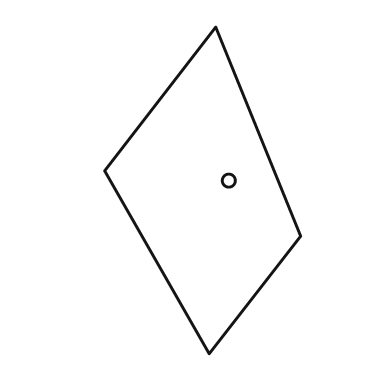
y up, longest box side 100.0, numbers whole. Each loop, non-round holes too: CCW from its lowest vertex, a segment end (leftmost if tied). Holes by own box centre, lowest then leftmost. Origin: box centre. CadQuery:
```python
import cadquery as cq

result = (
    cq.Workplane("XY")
    .moveTo(2.0, -50.0)
    .lineTo(30.0, -14.0)
    .lineTo(4.0, 50.0)
    .lineTo(-30.0, 6.0)
    .close()
    .moveTo(8.0, 3.0)
    .circle(2.0)
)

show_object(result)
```